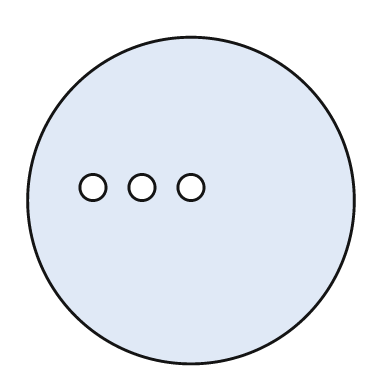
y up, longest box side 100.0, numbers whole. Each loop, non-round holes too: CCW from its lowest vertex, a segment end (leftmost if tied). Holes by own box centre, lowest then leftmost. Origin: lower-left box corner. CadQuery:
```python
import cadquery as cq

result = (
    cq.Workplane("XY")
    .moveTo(50.0, 50.0)
    .circle(50.0)
    .moveTo(20.0, 54.0)
    .circle(4.0)
    .moveTo(35.0, 54.0)
    .circle(4.0)
    .moveTo(50.0, 54.0)
    .circle(4.0)
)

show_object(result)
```